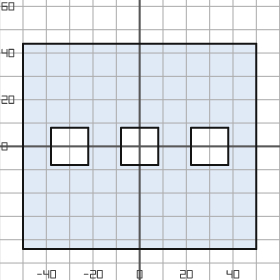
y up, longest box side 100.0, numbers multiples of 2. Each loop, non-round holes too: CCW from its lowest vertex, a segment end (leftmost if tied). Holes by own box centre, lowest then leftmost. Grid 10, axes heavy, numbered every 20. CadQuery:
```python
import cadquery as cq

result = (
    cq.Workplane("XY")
    .moveTo(-50.0, -44.0)
    .lineTo(50.0, -44.0)
    .lineTo(50.0, 44.0)
    .lineTo(-50.0, 44.0)
    .close()
    .moveTo(-38.0, -8.0)
    .lineTo(-22.0, -8.0)
    .lineTo(-22.0, 8.0)
    .lineTo(-38.0, 8.0)
    .close()
    .moveTo(-8.0, -8.0)
    .lineTo(8.0, -8.0)
    .lineTo(8.0, 8.0)
    .lineTo(-8.0, 8.0)
    .close()
    .moveTo(22.0, -8.0)
    .lineTo(38.0, -8.0)
    .lineTo(38.0, 8.0)
    .lineTo(22.0, 8.0)
    .close()
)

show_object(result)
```